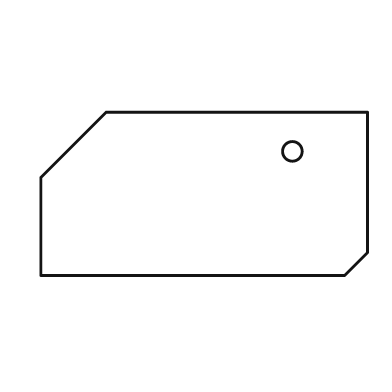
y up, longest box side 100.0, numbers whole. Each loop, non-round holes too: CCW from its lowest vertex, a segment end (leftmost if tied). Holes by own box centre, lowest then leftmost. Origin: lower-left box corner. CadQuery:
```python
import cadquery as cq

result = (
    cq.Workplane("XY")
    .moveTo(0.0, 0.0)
    .lineTo(93.0, 0.0)
    .lineTo(100.0, 7.0)
    .lineTo(100.0, 50.0)
    .lineTo(20.0, 50.0)
    .lineTo(0.0, 30.0)
    .close()
    .moveTo(77.0, 38.0)
    .circle(3.0)
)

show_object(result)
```